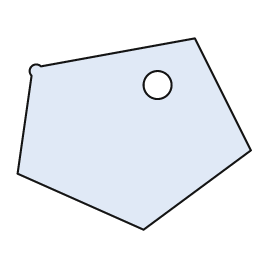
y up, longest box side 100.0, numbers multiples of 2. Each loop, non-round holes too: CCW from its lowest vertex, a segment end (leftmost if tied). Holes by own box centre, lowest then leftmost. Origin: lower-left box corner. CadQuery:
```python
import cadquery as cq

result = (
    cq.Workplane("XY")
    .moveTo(54.0, 0.0)
    .lineTo(100.0, 34.0)
    .lineTo(76.0, 82.0)
    .lineTo(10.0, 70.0)
    .threePointArc((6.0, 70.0), (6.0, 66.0))
    .lineTo(0.0, 24.0)
    .close()
    .moveTo(60.0, 62.0)
    .circle(6.0)
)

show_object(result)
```